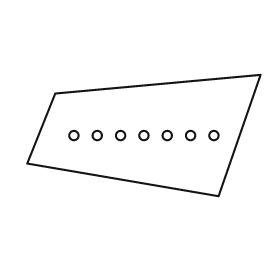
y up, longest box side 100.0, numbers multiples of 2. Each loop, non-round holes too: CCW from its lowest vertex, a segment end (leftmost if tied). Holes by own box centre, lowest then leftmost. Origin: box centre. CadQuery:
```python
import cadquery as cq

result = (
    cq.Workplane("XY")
    .moveTo(32.0, -26.0)
    .lineTo(50.0, 26.0)
    .lineTo(-38.0, 18.0)
    .lineTo(-50.0, -12.0)
    .close()
    .moveTo(-30.0, 0.0)
    .circle(2.0)
    .moveTo(-20.0, 0.0)
    .circle(2.0)
    .moveTo(-10.0, 0.0)
    .circle(2.0)
    .moveTo(0.0, 0.0)
    .circle(2.0)
    .moveTo(10.0, 0.0)
    .circle(2.0)
    .moveTo(20.0, 0.0)
    .circle(2.0)
    .moveTo(30.0, 0.0)
    .circle(2.0)
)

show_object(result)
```